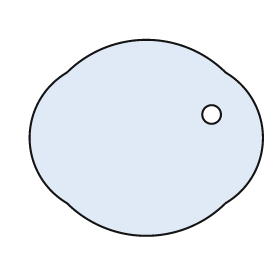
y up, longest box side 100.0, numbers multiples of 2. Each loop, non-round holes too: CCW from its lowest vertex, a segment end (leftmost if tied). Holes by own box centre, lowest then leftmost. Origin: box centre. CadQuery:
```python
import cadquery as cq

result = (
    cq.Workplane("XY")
    .moveTo(-34.0, -28.0)
    .threePointArc((0.0, -42.0), (34.0, -28.0))
    .threePointArc((50.0, 0.0), (34.0, 28.0))
    .threePointArc((0.0, 42.0), (-34.0, 28.0))
    .threePointArc((-50.0, 0.0), (-34.0, -28.0))
    .close()
    .moveTo(28.0, 10.0)
    .circle(4.0)
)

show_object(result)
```